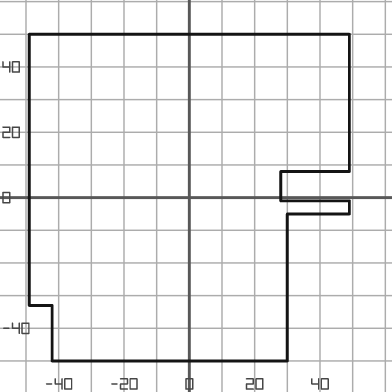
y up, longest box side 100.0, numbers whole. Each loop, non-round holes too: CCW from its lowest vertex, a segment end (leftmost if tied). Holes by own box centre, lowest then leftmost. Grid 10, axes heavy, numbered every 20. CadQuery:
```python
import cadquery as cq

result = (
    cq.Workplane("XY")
    .moveTo(-42.0, -50.0)
    .lineTo(30.0, -50.0)
    .lineTo(30.0, -5.0)
    .lineTo(49.0, -5.0)
    .lineTo(49.0, -1.0)
    .lineTo(28.0, -1.0)
    .lineTo(28.0, 8.0)
    .lineTo(49.0, 8.0)
    .lineTo(49.0, 50.0)
    .lineTo(-49.0, 50.0)
    .lineTo(-49.0, -33.0)
    .lineTo(-42.0, -33.0)
    .close()
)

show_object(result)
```